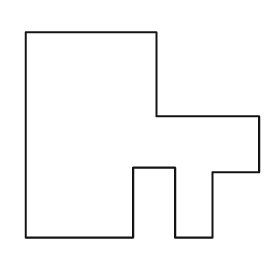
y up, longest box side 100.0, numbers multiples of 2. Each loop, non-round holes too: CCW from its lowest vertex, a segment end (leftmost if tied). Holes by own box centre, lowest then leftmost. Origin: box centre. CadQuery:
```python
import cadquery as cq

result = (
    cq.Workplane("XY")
    .moveTo(-50.0, -44.0)
    .lineTo(-4.0, -44.0)
    .lineTo(-4.0, -14.0)
    .lineTo(14.0, -14.0)
    .lineTo(14.0, -44.0)
    .lineTo(30.0, -44.0)
    .lineTo(30.0, -16.0)
    .lineTo(50.0, -16.0)
    .lineTo(50.0, 8.0)
    .lineTo(6.0, 8.0)
    .lineTo(6.0, 44.0)
    .lineTo(-50.0, 44.0)
    .close()
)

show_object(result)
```